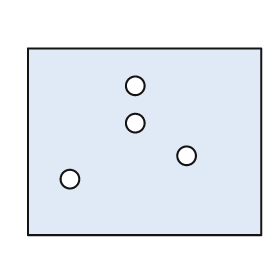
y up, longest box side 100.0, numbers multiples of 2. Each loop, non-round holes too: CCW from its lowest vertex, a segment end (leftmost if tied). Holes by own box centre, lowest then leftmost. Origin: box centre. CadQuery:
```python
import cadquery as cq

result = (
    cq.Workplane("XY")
    .moveTo(-50.0, -40.0)
    .lineTo(50.0, -40.0)
    .lineTo(50.0, 40.0)
    .lineTo(-50.0, 40.0)
    .close()
    .moveTo(-32.0, -16.0)
    .circle(4.0)
    .moveTo(18.0, -6.0)
    .circle(4.0)
    .moveTo(-4.0, 8.0)
    .circle(4.0)
    .moveTo(-4.0, 24.0)
    .circle(4.0)
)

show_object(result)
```